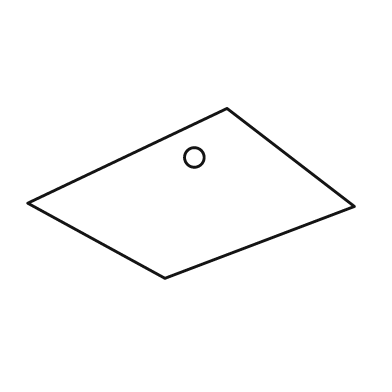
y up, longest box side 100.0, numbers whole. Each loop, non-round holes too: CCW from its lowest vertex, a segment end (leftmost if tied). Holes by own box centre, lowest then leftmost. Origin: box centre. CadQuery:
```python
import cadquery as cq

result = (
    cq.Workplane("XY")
    .moveTo(-8.0, -26.0)
    .lineTo(50.0, -4.0)
    .lineTo(11.0, 26.0)
    .lineTo(-50.0, -3.0)
    .close()
    .moveTo(1.0, 11.0)
    .circle(3.0)
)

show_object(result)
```